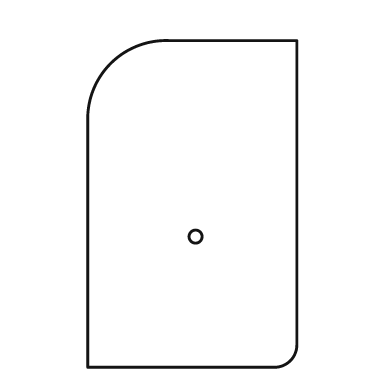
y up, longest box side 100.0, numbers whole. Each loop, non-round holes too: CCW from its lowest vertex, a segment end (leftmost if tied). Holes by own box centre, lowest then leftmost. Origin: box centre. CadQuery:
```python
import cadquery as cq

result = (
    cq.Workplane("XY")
    .moveTo(-32.0, -50.0)
    .lineTo(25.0, -50.0)
    .threePointArc((30.0, -48.0), (32.0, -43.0))
    .lineTo(32.0, 50.0)
    .lineTo(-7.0, 50.0)
    .threePointArc((-25.0, 43.0), (-32.0, 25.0))
    .close()
    .moveTo(1.0, -10.0)
    .circle(2.0)
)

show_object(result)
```